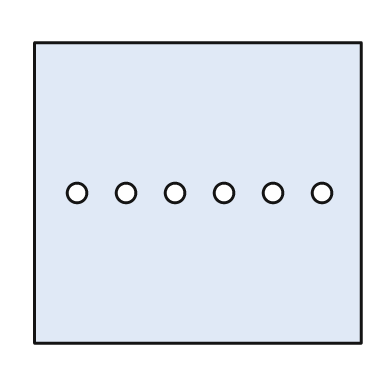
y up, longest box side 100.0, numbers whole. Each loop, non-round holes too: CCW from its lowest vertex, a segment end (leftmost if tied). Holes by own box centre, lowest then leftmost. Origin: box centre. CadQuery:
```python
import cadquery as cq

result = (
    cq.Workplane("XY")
    .moveTo(-50.0, -46.0)
    .lineTo(50.0, -46.0)
    .lineTo(50.0, 46.0)
    .lineTo(-50.0, 46.0)
    .close()
    .moveTo(-37.0, 0.0)
    .circle(3.0)
    .moveTo(-22.0, 0.0)
    .circle(3.0)
    .moveTo(-7.0, 0.0)
    .circle(3.0)
    .moveTo(8.0, 0.0)
    .circle(3.0)
    .moveTo(23.0, 0.0)
    .circle(3.0)
    .moveTo(38.0, 0.0)
    .circle(3.0)
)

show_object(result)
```